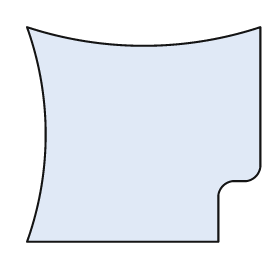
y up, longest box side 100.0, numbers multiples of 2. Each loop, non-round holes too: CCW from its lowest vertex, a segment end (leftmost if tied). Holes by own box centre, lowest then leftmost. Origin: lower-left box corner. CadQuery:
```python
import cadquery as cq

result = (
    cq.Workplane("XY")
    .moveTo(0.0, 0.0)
    .lineTo(82.0, 0.0)
    .lineTo(82.0, 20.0)
    .threePointArc((84.0, 24.0), (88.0, 26.0))
    .lineTo(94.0, 26.0)
    .threePointArc((98.0, 28.0), (100.0, 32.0))
    .lineTo(100.0, 92.0)
    .threePointArc((50.0, 84.0), (0.0, 92.0))
    .threePointArc((8.0, 46.0), (0.0, 0.0))
    .close()
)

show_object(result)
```